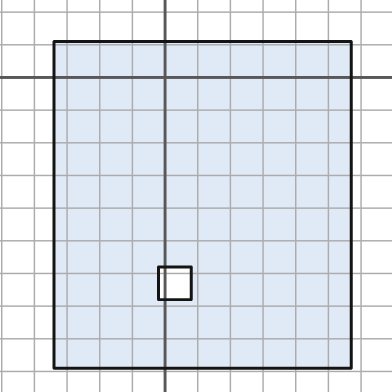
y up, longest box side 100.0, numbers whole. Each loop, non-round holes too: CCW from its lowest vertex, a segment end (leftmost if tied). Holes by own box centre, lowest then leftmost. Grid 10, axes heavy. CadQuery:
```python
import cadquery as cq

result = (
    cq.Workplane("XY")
    .moveTo(-34.0, -89.0)
    .lineTo(57.0, -89.0)
    .lineTo(57.0, 11.0)
    .lineTo(-34.0, 11.0)
    .close()
    .moveTo(-2.0, -68.0)
    .lineTo(8.0, -68.0)
    .lineTo(8.0, -58.0)
    .lineTo(-2.0, -58.0)
    .close()
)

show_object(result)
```